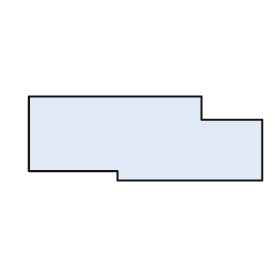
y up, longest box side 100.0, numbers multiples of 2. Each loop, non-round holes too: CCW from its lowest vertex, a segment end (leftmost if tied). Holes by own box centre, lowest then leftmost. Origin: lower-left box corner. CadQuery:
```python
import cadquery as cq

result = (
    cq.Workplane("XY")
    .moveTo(38.0, 0.0)
    .lineTo(100.0, 0.0)
    .lineTo(100.0, 26.0)
    .lineTo(74.0, 26.0)
    .lineTo(74.0, 36.0)
    .lineTo(0.0, 36.0)
    .lineTo(0.0, 4.0)
    .lineTo(38.0, 4.0)
    .close()
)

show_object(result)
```